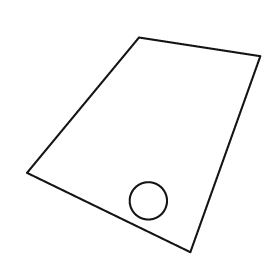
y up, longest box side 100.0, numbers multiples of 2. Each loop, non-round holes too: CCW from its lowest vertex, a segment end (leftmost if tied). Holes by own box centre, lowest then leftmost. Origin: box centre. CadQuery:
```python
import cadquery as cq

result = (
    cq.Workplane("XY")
    .moveTo(20.0, -46.0)
    .lineTo(50.0, 38.0)
    .lineTo(-2.0, 46.0)
    .lineTo(-50.0, -12.0)
    .close()
    .moveTo(2.0, -24.0)
    .circle(8.0)
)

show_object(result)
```